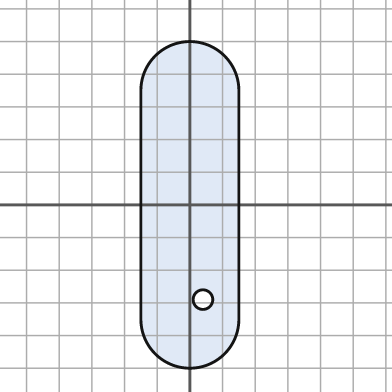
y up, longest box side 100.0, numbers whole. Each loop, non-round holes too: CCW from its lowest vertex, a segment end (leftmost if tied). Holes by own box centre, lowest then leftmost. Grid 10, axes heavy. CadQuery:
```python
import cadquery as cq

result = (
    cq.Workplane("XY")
    .moveTo(-15.0, -35.0)
    .threePointArc((0.0, -50.0), (15.0, -35.0))
    .lineTo(15.0, 35.0)
    .threePointArc((0.0, 50.0), (-15.0, 35.0))
    .close()
    .moveTo(4.0, -29.0)
    .circle(3.0)
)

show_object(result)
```